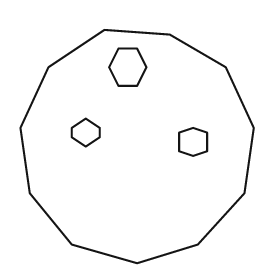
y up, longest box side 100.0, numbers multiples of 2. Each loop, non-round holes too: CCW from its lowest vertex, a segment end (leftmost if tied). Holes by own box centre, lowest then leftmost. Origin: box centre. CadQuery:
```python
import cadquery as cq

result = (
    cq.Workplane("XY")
    .moveTo(0.0, -50.0)
    .lineTo(26.0, -42.0)
    .lineTo(46.0, -20.0)
    .lineTo(50.0, 8.0)
    .lineTo(38.0, 34.0)
    .lineTo(14.0, 48.0)
    .lineTo(-14.0, 50.0)
    .lineTo(-38.0, 34.0)
    .lineTo(-50.0, 8.0)
    .lineTo(-46.0, -20.0)
    .lineTo(-28.0, -42.0)
    .close()
    .moveTo(24.0, -4.0)
    .lineTo(30.0, -2.0)
    .lineTo(30.0, 6.0)
    .lineTo(24.0, 8.0)
    .lineTo(18.0, 6.0)
    .lineTo(18.0, -2.0)
    .close()
    .moveTo(-22.0, 0.0)
    .lineTo(-16.0, 4.0)
    .lineTo(-16.0, 8.0)
    .lineTo(-22.0, 12.0)
    .lineTo(-28.0, 8.0)
    .lineTo(-28.0, 4.0)
    .close()
    .moveTo(-8.0, 26.0)
    .lineTo(0.0, 26.0)
    .lineTo(4.0, 34.0)
    .lineTo(0.0, 42.0)
    .lineTo(-8.0, 42.0)
    .lineTo(-12.0, 34.0)
    .close()
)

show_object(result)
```